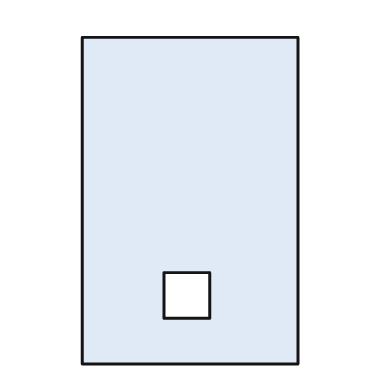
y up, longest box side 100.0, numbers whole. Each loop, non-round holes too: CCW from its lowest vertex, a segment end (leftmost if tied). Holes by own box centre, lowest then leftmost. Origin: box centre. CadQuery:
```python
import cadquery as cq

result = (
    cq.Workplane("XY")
    .moveTo(-33.0, -50.0)
    .lineTo(33.0, -50.0)
    .lineTo(33.0, 50.0)
    .lineTo(-33.0, 50.0)
    .close()
    .moveTo(-8.0, -36.0)
    .lineTo(6.0, -36.0)
    .lineTo(6.0, -22.0)
    .lineTo(-8.0, -22.0)
    .close()
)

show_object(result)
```